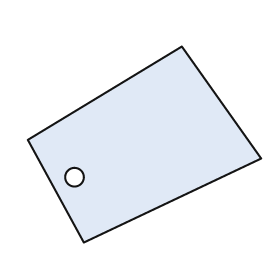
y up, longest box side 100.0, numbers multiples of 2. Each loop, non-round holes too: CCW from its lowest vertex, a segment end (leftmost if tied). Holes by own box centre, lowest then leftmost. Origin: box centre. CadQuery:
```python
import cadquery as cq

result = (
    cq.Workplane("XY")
    .moveTo(-26.0, -42.0)
    .lineTo(50.0, -6.0)
    .lineTo(16.0, 42.0)
    .lineTo(-50.0, 2.0)
    .close()
    .moveTo(-30.0, -14.0)
    .circle(4.0)
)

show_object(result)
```